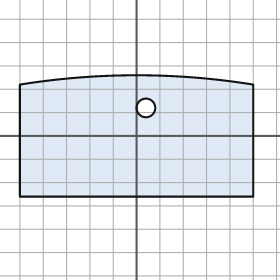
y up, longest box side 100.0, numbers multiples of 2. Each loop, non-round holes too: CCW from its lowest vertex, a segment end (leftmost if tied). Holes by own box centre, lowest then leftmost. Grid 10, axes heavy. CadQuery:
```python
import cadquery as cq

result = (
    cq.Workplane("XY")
    .moveTo(-50.0, -26.0)
    .lineTo(50.0, -26.0)
    .lineTo(50.0, 22.0)
    .threePointArc((0.0, 26.0), (-50.0, 22.0))
    .close()
    .moveTo(4.0, 12.0)
    .circle(4.0)
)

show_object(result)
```